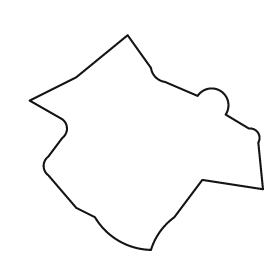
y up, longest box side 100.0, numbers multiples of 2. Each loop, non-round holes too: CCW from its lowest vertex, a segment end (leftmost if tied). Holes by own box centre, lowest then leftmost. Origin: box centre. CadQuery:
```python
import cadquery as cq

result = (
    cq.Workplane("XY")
    .moveTo(2.0, -46.0)
    .threePointArc((6.0, -38.0), (12.0, -32.0))
    .lineTo(24.0, -16.0)
    .lineTo(50.0, -20.0)
    .lineTo(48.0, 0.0)
    .threePointArc((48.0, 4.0), (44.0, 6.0))
    .lineTo(34.0, 12.0)
    .threePointArc((32.0, 22.0), (22.0, 20.0))
    .lineTo(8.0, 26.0)
    .threePointArc((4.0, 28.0), (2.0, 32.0))
    .lineTo(-8.0, 46.0)
    .lineTo(-30.0, 28.0)
    .lineTo(-50.0, 18.0)
    .lineTo(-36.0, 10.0)
    .threePointArc((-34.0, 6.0), (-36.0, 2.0))
    .lineTo(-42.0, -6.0)
    .threePointArc((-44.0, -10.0), (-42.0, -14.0))
    .lineTo(-30.0, -28.0)
    .lineTo(-22.0, -32.0)
    .threePointArc((-12.0, -42.0), (2.0, -46.0))
    .close()
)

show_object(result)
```